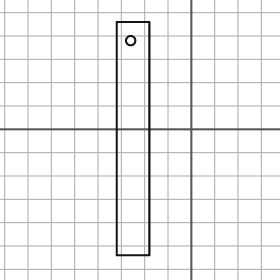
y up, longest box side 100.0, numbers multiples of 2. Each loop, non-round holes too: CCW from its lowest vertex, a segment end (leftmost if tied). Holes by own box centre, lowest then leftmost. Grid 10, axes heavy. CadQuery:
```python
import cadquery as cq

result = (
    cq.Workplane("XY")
    .moveTo(-32.0, -54.0)
    .lineTo(-18.0, -54.0)
    .lineTo(-18.0, 46.0)
    .lineTo(-32.0, 46.0)
    .close()
    .moveTo(-26.0, 38.0)
    .circle(2.0)
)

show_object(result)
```